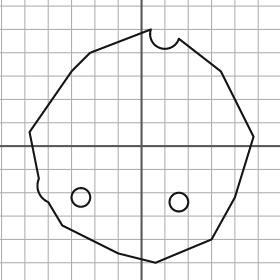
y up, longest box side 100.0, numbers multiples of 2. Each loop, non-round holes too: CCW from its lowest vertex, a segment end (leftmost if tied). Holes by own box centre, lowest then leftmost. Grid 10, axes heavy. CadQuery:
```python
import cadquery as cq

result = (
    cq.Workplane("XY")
    .moveTo(6.0, -50.0)
    .lineTo(30.0, -40.0)
    .lineTo(40.0, -22.0)
    .lineTo(48.0, 4.0)
    .lineTo(34.0, 32.0)
    .lineTo(16.0, 46.0)
    .threePointArc((8.0, 42.0), (4.0, 50.0))
    .lineTo(-22.0, 40.0)
    .lineTo(-30.0, 32.0)
    .lineTo(-48.0, 6.0)
    .lineTo(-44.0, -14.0)
    .threePointArc((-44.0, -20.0), (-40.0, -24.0))
    .lineTo(-34.0, -34.0)
    .lineTo(-10.0, -46.0)
    .close()
    .moveTo(16.0, -24.0)
    .circle(4.0)
    .moveTo(-26.0, -22.0)
    .circle(4.0)
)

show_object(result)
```